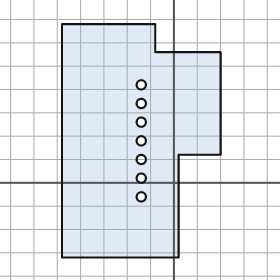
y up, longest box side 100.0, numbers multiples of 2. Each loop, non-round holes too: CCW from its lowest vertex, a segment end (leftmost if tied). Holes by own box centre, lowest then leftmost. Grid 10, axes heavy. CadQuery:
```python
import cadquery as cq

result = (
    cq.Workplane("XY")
    .moveTo(-48.0, -32.0)
    .lineTo(2.0, -32.0)
    .lineTo(2.0, 12.0)
    .lineTo(20.0, 12.0)
    .lineTo(20.0, 56.0)
    .lineTo(-8.0, 56.0)
    .lineTo(-8.0, 68.0)
    .lineTo(-48.0, 68.0)
    .close()
    .moveTo(-14.0, -6.0)
    .circle(2.0)
    .moveTo(-14.0, 2.0)
    .circle(2.0)
    .moveTo(-14.0, 10.0)
    .circle(2.0)
    .moveTo(-14.0, 18.0)
    .circle(2.0)
    .moveTo(-14.0, 26.0)
    .circle(2.0)
    .moveTo(-14.0, 34.0)
    .circle(2.0)
    .moveTo(-14.0, 42.0)
    .circle(2.0)
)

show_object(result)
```